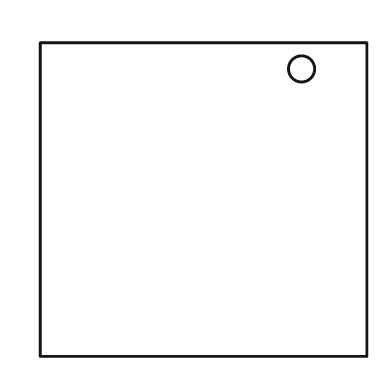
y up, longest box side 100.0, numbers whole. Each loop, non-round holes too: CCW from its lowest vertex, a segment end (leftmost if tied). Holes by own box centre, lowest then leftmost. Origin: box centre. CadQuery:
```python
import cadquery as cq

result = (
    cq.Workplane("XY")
    .moveTo(-50.0, -48.0)
    .lineTo(50.0, -48.0)
    .lineTo(50.0, 48.0)
    .lineTo(-50.0, 48.0)
    .close()
    .moveTo(30.0, 40.0)
    .circle(4.0)
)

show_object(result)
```